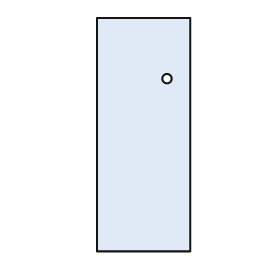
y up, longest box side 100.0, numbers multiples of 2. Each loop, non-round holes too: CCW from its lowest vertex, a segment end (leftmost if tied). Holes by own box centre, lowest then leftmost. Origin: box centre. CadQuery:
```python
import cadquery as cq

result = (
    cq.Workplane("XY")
    .moveTo(-20.0, -50.0)
    .lineTo(20.0, -50.0)
    .lineTo(20.0, 50.0)
    .lineTo(-20.0, 50.0)
    .close()
    .moveTo(10.0, 24.0)
    .circle(2.0)
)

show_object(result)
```